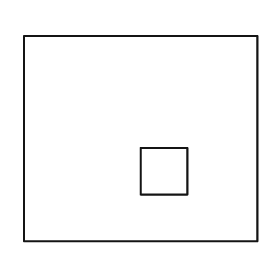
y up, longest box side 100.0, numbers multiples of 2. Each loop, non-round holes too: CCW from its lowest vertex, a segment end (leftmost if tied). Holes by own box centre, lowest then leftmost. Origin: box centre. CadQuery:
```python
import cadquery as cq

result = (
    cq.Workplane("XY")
    .moveTo(-50.0, -44.0)
    .lineTo(50.0, -44.0)
    .lineTo(50.0, 44.0)
    .lineTo(-50.0, 44.0)
    .close()
    .moveTo(0.0, -24.0)
    .lineTo(20.0, -24.0)
    .lineTo(20.0, -4.0)
    .lineTo(0.0, -4.0)
    .close()
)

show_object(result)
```